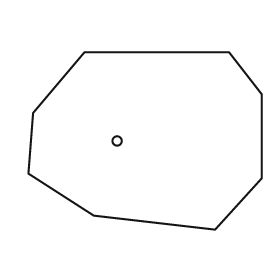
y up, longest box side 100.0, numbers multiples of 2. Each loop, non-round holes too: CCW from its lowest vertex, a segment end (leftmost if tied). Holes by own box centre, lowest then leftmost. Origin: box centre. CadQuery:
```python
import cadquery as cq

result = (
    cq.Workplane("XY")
    .moveTo(30.0, -38.0)
    .lineTo(50.0, -16.0)
    .lineTo(50.0, 20.0)
    .lineTo(36.0, 38.0)
    .lineTo(-26.0, 38.0)
    .lineTo(-48.0, 12.0)
    .lineTo(-50.0, -14.0)
    .lineTo(-22.0, -32.0)
    .close()
    .moveTo(-12.0, 0.0)
    .circle(2.0)
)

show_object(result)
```